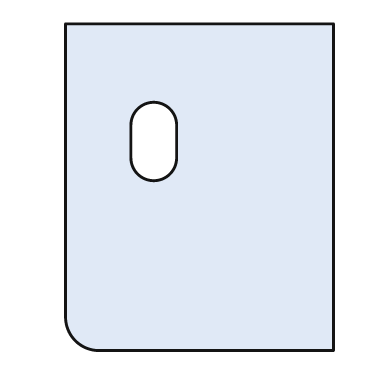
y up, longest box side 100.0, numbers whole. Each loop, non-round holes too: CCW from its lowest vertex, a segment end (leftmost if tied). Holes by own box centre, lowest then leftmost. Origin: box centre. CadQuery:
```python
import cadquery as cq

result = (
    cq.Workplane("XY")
    .moveTo(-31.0, -50.0)
    .lineTo(41.0, -50.0)
    .lineTo(41.0, 50.0)
    .lineTo(-41.0, 50.0)
    .lineTo(-41.0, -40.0)
    .threePointArc((-38.0, -47.0), (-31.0, -50.0))
    .close()
    .moveTo(-21.0, 9.0)
    .threePointArc((-14.0, 2.0), (-7.0, 9.0))
    .lineTo(-7.0, 19.0)
    .threePointArc((-14.0, 26.0), (-21.0, 19.0))
    .close()
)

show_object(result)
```